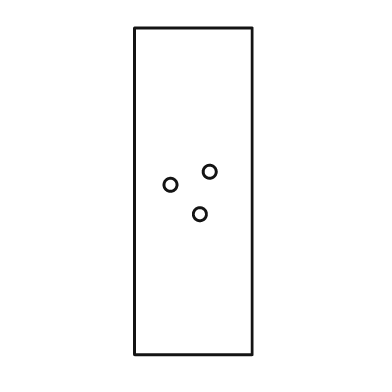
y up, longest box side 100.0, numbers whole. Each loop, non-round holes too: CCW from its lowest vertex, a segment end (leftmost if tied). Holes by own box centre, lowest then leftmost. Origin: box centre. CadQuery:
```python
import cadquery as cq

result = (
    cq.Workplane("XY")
    .moveTo(-18.0, -50.0)
    .lineTo(18.0, -50.0)
    .lineTo(18.0, 50.0)
    .lineTo(-18.0, 50.0)
    .close()
    .moveTo(2.0, -7.0)
    .circle(2.0)
    .moveTo(-7.0, 2.0)
    .circle(2.0)
    .moveTo(5.0, 6.0)
    .circle(2.0)
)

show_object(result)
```